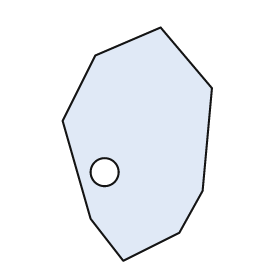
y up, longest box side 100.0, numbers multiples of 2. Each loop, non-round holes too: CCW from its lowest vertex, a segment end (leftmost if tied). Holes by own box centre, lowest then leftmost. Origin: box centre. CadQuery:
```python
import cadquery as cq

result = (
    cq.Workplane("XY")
    .moveTo(-6.0, -50.0)
    .lineTo(18.0, -38.0)
    .lineTo(28.0, -20.0)
    .lineTo(32.0, 24.0)
    .lineTo(10.0, 50.0)
    .lineTo(-18.0, 38.0)
    .lineTo(-32.0, 10.0)
    .lineTo(-20.0, -32.0)
    .close()
    .moveTo(-14.0, -12.0)
    .circle(6.0)
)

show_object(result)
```